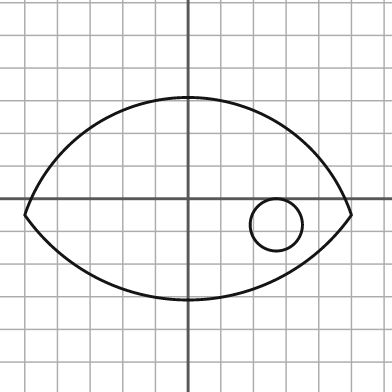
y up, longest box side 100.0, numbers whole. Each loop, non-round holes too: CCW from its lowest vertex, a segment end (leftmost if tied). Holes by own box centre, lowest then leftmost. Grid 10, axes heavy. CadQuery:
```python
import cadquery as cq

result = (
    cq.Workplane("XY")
    .moveTo(-50.0, -5.0)
    .threePointArc((0.0, -31.0), (50.0, -5.0))
    .threePointArc((0.0, 31.0), (-50.0, -5.0))
    .close()
    .moveTo(27.0, -8.0)
    .circle(8.0)
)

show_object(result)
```